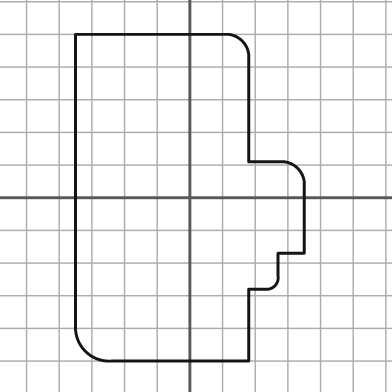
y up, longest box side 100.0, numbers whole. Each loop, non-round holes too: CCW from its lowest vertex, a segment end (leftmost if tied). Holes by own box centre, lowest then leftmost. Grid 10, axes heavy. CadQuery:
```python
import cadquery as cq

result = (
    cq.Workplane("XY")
    .moveTo(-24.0, -50.0)
    .lineTo(18.0, -50.0)
    .lineTo(18.0, -28.0)
    .lineTo(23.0, -28.0)
    .threePointArc((26.0, -27.0), (27.0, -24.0))
    .lineTo(27.0, -17.0)
    .lineTo(35.0, -17.0)
    .lineTo(35.0, 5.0)
    .threePointArc((33.0, 9.0), (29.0, 11.0))
    .lineTo(18.0, 11.0)
    .lineTo(18.0, 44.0)
    .threePointArc((16.0, 48.0), (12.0, 50.0))
    .lineTo(-35.0, 50.0)
    .lineTo(-35.0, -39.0)
    .threePointArc((-32.0, -47.0), (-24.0, -50.0))
    .close()
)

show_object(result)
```